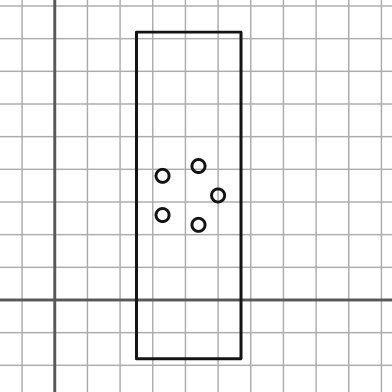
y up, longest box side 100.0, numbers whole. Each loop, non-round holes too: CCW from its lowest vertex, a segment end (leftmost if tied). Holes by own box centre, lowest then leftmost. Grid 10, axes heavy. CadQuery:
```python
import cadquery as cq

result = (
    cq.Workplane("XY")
    .moveTo(25.0, -18.0)
    .lineTo(57.0, -18.0)
    .lineTo(57.0, 82.0)
    .lineTo(25.0, 82.0)
    .close()
    .moveTo(44.0, 23.0)
    .circle(2.0)
    .moveTo(33.0, 26.0)
    .circle(2.0)
    .moveTo(50.0, 32.0)
    .circle(2.0)
    .moveTo(33.0, 38.0)
    .circle(2.0)
    .moveTo(44.0, 41.0)
    .circle(2.0)
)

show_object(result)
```